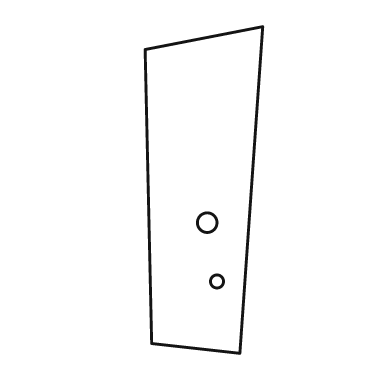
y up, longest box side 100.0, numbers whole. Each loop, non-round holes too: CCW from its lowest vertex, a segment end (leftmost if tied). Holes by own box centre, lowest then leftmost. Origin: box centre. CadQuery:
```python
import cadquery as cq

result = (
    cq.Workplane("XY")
    .moveTo(11.0, -50.0)
    .lineTo(18.0, 50.0)
    .lineTo(-18.0, 43.0)
    .lineTo(-16.0, -47.0)
    .close()
    .moveTo(4.0, -28.0)
    .circle(2.0)
    .moveTo(1.0, -10.0)
    .circle(3.0)
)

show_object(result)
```